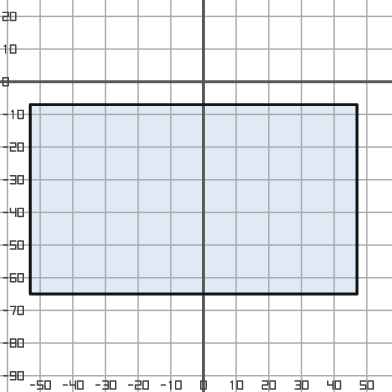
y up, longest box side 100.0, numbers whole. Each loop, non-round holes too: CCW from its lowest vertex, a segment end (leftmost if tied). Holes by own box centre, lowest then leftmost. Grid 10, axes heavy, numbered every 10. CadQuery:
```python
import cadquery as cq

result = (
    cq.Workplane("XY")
    .moveTo(-53.0, -65.0)
    .lineTo(47.0, -65.0)
    .lineTo(47.0, -7.0)
    .lineTo(-53.0, -7.0)
    .close()
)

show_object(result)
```